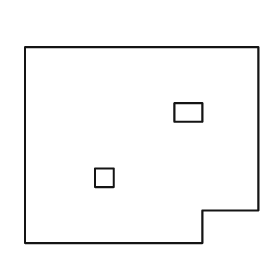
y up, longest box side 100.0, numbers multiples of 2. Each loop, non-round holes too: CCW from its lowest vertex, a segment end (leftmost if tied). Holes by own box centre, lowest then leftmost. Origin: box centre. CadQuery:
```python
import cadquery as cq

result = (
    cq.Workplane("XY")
    .moveTo(-50.0, -42.0)
    .lineTo(26.0, -42.0)
    .lineTo(26.0, -28.0)
    .lineTo(50.0, -28.0)
    .lineTo(50.0, 42.0)
    .lineTo(-50.0, 42.0)
    .close()
    .moveTo(-20.0, -18.0)
    .lineTo(-12.0, -18.0)
    .lineTo(-12.0, -10.0)
    .lineTo(-20.0, -10.0)
    .close()
    .moveTo(14.0, 10.0)
    .lineTo(26.0, 10.0)
    .lineTo(26.0, 18.0)
    .lineTo(14.0, 18.0)
    .close()
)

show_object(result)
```